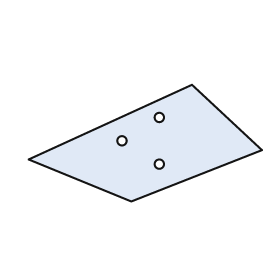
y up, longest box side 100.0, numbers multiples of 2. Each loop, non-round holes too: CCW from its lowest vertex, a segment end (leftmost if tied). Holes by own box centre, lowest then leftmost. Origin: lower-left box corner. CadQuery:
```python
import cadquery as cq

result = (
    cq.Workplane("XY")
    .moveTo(44.0, 0.0)
    .lineTo(100.0, 22.0)
    .lineTo(70.0, 50.0)
    .lineTo(0.0, 18.0)
    .close()
    .moveTo(56.0, 16.0)
    .circle(2.0)
    .moveTo(40.0, 26.0)
    .circle(2.0)
    .moveTo(56.0, 36.0)
    .circle(2.0)
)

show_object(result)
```